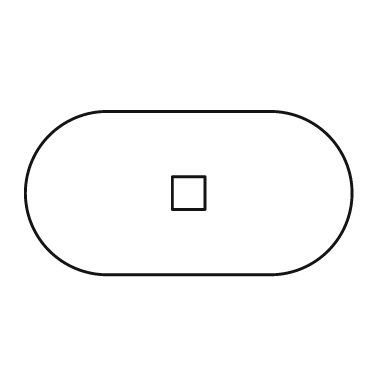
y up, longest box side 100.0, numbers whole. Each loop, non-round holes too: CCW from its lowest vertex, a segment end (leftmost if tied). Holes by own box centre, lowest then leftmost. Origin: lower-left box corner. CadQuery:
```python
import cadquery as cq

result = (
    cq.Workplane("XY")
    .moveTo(25.0, 0.0)
    .lineTo(75.0, 0.0)
    .threePointArc((100.0, 25.0), (75.0, 50.0))
    .lineTo(25.0, 50.0)
    .threePointArc((0.0, 25.0), (25.0, 0.0))
    .close()
    .moveTo(45.0, 20.0)
    .lineTo(55.0, 20.0)
    .lineTo(55.0, 30.0)
    .lineTo(45.0, 30.0)
    .close()
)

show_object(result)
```